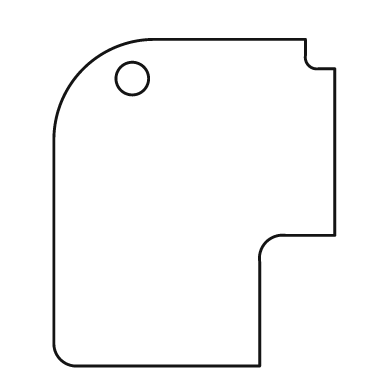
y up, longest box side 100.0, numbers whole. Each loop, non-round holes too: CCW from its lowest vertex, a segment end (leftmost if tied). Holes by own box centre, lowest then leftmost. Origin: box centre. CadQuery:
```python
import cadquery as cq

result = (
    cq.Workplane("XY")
    .moveTo(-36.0, -50.0)
    .lineTo(20.0, -50.0)
    .lineTo(20.0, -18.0)
    .threePointArc((22.0, -12.0), (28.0, -10.0))
    .lineTo(43.0, -10.0)
    .lineTo(43.0, 41.0)
    .lineTo(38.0, 41.0)
    .threePointArc((35.0, 42.0), (34.0, 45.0))
    .lineTo(34.0, 50.0)
    .lineTo(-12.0, 50.0)
    .threePointArc((-34.0, 41.0), (-43.0, 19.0))
    .lineTo(-43.0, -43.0)
    .threePointArc((-41.0, -48.0), (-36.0, -50.0))
    .close()
    .moveTo(-19.0, 38.0)
    .circle(5.0)
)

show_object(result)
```